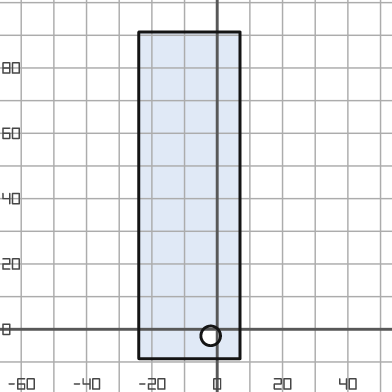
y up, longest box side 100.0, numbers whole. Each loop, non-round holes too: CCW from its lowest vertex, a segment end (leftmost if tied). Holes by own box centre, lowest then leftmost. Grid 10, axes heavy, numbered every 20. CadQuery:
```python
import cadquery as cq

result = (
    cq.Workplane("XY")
    .moveTo(-24.0, -9.0)
    .lineTo(7.0, -9.0)
    .lineTo(7.0, 91.0)
    .lineTo(-24.0, 91.0)
    .close()
    .moveTo(-2.0, -2.0)
    .circle(3.0)
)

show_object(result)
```